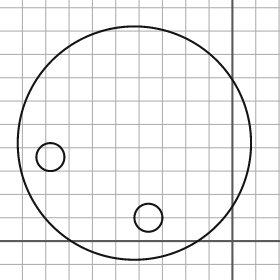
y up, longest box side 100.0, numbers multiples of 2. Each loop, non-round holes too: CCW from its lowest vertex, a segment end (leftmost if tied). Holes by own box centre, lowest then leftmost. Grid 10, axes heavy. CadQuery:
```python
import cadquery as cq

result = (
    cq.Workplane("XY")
    .moveTo(-42.0, 42.0)
    .circle(50.0)
    .moveTo(-36.0, 10.0)
    .circle(6.0)
    .moveTo(-78.0, 36.0)
    .circle(6.0)
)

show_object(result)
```